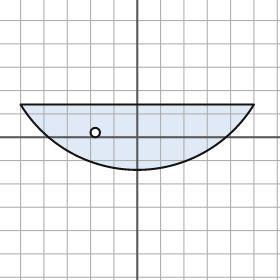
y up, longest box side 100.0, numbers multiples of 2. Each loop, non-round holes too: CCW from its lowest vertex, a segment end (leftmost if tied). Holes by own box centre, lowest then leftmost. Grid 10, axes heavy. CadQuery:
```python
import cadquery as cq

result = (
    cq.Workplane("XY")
    .moveTo(-50.0, 14.0)
    .threePointArc((0.0, -14.0), (50.0, 14.0))
    .close()
    .moveTo(-18.0, 2.0)
    .circle(2.0)
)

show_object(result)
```